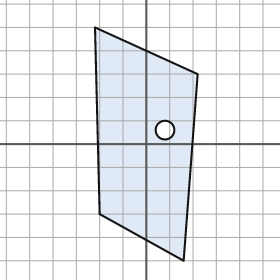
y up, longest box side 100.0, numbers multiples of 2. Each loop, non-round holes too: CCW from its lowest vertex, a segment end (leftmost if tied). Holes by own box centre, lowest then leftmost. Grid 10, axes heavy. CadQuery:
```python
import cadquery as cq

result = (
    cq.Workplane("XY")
    .moveTo(16.0, -50.0)
    .lineTo(22.0, 30.0)
    .lineTo(-22.0, 50.0)
    .lineTo(-20.0, -30.0)
    .close()
    .moveTo(8.0, 6.0)
    .circle(4.0)
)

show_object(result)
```